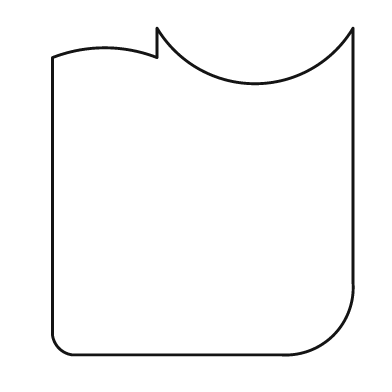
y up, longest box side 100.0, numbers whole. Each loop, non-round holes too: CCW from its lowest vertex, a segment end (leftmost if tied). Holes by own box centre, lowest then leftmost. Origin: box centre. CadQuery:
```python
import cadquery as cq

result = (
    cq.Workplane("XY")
    .moveTo(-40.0, -50.0)
    .lineTo(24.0, -50.0)
    .threePointArc((40.0, -44.0), (46.0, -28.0))
    .lineTo(46.0, 50.0)
    .threePointArc((16.0, 33.0), (-14.0, 50.0))
    .lineTo(-14.0, 41.0)
    .threePointArc((-30.0, 44.0), (-46.0, 41.0))
    .lineTo(-46.0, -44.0)
    .threePointArc((-44.0, -48.0), (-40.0, -50.0))
    .close()
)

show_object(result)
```